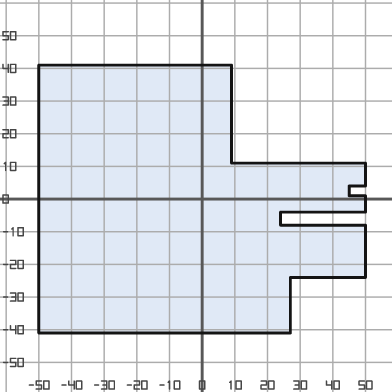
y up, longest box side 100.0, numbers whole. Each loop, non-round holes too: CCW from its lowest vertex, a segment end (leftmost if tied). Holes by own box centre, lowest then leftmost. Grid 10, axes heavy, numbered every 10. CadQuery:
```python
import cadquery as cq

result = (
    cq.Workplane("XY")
    .moveTo(-50.0, -41.0)
    .lineTo(27.0, -41.0)
    .lineTo(27.0, -24.0)
    .lineTo(50.0, -24.0)
    .lineTo(50.0, -8.0)
    .lineTo(24.0, -8.0)
    .lineTo(24.0, -4.0)
    .lineTo(50.0, -4.0)
    .lineTo(50.0, 1.0)
    .lineTo(45.0, 1.0)
    .lineTo(45.0, 4.0)
    .lineTo(50.0, 4.0)
    .lineTo(50.0, 11.0)
    .lineTo(9.0, 11.0)
    .lineTo(9.0, 41.0)
    .lineTo(-50.0, 41.0)
    .close()
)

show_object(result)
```